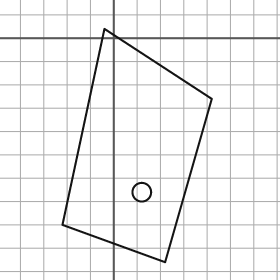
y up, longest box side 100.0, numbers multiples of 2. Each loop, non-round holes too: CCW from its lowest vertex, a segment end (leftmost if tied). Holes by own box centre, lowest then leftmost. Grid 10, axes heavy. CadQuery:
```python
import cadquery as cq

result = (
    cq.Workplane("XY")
    .moveTo(22.0, -96.0)
    .lineTo(42.0, -26.0)
    .lineTo(-4.0, 4.0)
    .lineTo(-22.0, -80.0)
    .close()
    .moveTo(12.0, -66.0)
    .circle(4.0)
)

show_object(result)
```